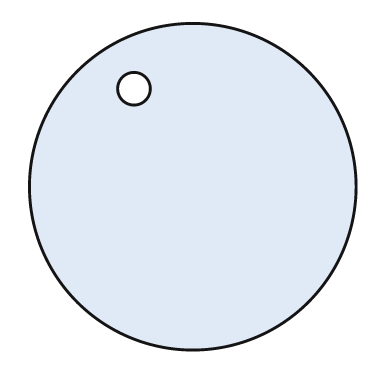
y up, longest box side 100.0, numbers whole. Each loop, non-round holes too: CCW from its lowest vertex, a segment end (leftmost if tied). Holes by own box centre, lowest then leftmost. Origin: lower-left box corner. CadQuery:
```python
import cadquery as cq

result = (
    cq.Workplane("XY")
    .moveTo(50.0, 50.0)
    .circle(50.0)
    .moveTo(32.0, 80.0)
    .circle(5.0)
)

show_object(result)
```